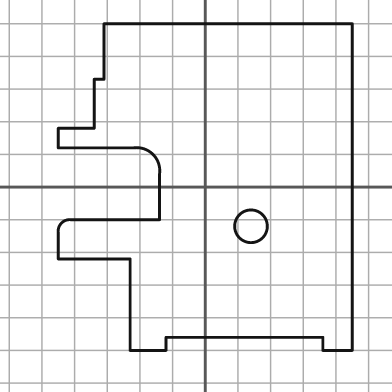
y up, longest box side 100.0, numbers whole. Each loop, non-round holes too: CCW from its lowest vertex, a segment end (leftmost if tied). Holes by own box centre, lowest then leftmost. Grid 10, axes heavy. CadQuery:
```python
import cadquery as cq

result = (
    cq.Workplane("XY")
    .moveTo(-23.0, -50.0)
    .lineTo(-12.0, -50.0)
    .lineTo(-12.0, -46.0)
    .lineTo(36.0, -46.0)
    .lineTo(36.0, -50.0)
    .lineTo(45.0, -50.0)
    .lineTo(45.0, 50.0)
    .lineTo(-31.0, 50.0)
    .lineTo(-31.0, 33.0)
    .lineTo(-34.0, 33.0)
    .lineTo(-34.0, 18.0)
    .lineTo(-45.0, 18.0)
    .lineTo(-45.0, 12.0)
    .lineTo(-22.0, 12.0)
    .threePointArc((-16.0, 10.0), (-14.0, 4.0))
    .lineTo(-14.0, -10.0)
    .lineTo(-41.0, -10.0)
    .threePointArc((-44.0, -11.0), (-45.0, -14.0))
    .lineTo(-45.0, -22.0)
    .lineTo(-23.0, -22.0)
    .close()
    .moveTo(14.0, -12.0)
    .circle(5.0)
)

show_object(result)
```